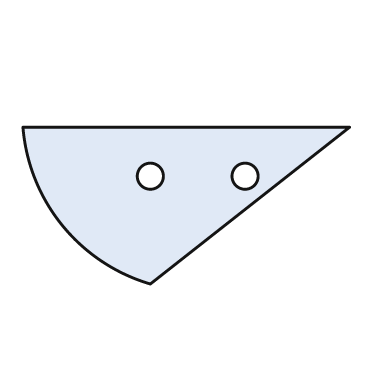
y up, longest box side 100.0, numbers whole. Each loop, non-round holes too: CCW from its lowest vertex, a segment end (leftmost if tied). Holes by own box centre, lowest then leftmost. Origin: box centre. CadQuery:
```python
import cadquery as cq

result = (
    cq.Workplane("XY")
    .moveTo(-11.0, -24.0)
    .lineTo(50.0, 24.0)
    .lineTo(-50.0, 24.0)
    .threePointArc((-38.0, -6.0), (-11.0, -24.0))
    .close()
    .moveTo(-11.0, 9.0)
    .circle(4.0)
    .moveTo(18.0, 9.0)
    .circle(4.0)
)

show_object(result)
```